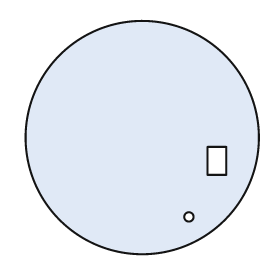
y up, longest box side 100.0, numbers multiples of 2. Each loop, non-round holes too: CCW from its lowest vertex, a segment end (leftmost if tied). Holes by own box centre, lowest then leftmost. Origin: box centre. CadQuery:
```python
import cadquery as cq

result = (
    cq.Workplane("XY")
    .moveTo(0.0, 0.0)
    .circle(50.0)
    .moveTo(20.0, -34.0)
    .circle(2.0)
    .moveTo(28.0, -16.0)
    .lineTo(36.0, -16.0)
    .lineTo(36.0, -4.0)
    .lineTo(28.0, -4.0)
    .close()
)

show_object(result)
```